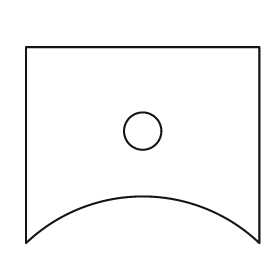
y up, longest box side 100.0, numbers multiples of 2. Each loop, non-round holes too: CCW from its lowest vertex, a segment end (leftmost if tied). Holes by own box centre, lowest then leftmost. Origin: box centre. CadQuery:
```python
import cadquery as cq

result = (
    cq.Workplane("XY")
    .moveTo(-50.0, -42.0)
    .threePointArc((0.0, -22.0), (50.0, -42.0))
    .lineTo(50.0, 42.0)
    .lineTo(-50.0, 42.0)
    .close()
    .moveTo(0.0, 6.0)
    .circle(8.0)
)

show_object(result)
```